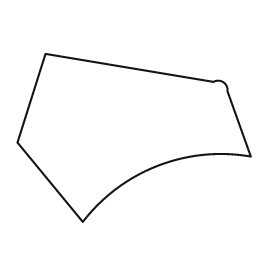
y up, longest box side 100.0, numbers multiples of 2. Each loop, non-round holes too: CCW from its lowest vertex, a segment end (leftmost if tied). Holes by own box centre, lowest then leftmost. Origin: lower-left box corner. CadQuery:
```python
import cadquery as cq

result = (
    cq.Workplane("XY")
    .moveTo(28.0, 0.0)
    .threePointArc((60.0, 24.0), (100.0, 28.0))
    .lineTo(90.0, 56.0)
    .threePointArc((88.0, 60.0), (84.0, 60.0))
    .lineTo(12.0, 72.0)
    .lineTo(0.0, 34.0)
    .close()
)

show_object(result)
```